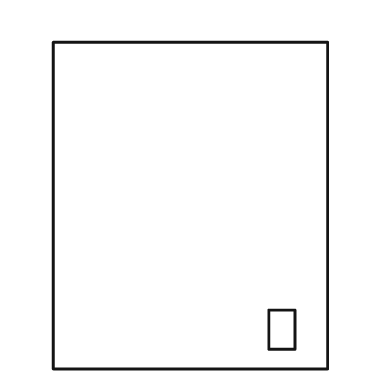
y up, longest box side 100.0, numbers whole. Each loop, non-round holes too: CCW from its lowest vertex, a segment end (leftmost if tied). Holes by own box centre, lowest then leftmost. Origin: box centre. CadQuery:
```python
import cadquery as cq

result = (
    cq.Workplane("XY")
    .moveTo(-42.0, -50.0)
    .lineTo(42.0, -50.0)
    .lineTo(42.0, 50.0)
    .lineTo(-42.0, 50.0)
    .close()
    .moveTo(24.0, -44.0)
    .lineTo(32.0, -44.0)
    .lineTo(32.0, -32.0)
    .lineTo(24.0, -32.0)
    .close()
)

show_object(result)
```